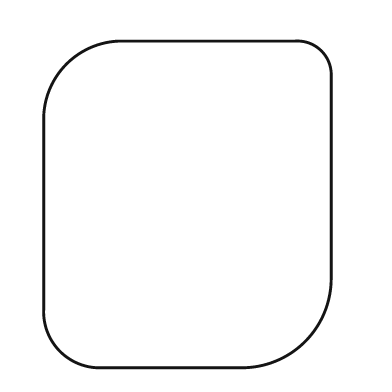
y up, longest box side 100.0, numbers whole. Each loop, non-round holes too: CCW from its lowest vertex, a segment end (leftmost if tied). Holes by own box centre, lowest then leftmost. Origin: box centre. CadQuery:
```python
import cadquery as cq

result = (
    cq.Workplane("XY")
    .moveTo(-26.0, -50.0)
    .lineTo(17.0, -50.0)
    .threePointArc((36.0, -42.0), (44.0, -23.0))
    .lineTo(44.0, 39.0)
    .threePointArc((41.0, 47.0), (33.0, 50.0))
    .lineTo(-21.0, 50.0)
    .threePointArc((-37.0, 43.0), (-44.0, 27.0))
    .lineTo(-44.0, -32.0)
    .threePointArc((-39.0, -45.0), (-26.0, -50.0))
    .close()
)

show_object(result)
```